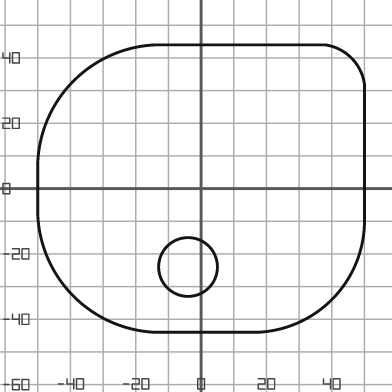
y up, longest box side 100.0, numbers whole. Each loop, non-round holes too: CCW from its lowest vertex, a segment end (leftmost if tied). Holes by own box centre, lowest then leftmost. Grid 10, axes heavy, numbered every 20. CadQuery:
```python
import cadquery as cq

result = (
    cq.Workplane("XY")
    .moveTo(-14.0, -44.0)
    .lineTo(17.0, -44.0)
    .threePointArc((40.0, -34.0), (50.0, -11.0))
    .lineTo(50.0, 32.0)
    .threePointArc((46.0, 40.0), (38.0, 44.0))
    .lineTo(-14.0, 44.0)
    .threePointArc((-39.0, 33.0), (-50.0, 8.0))
    .lineTo(-50.0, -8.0)
    .threePointArc((-39.0, -33.0), (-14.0, -44.0))
    .close()
    .moveTo(-4.0, -24.0)
    .circle(9.0)
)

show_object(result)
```